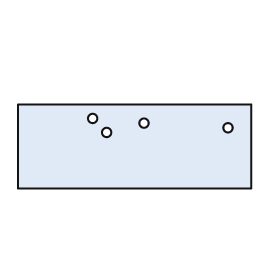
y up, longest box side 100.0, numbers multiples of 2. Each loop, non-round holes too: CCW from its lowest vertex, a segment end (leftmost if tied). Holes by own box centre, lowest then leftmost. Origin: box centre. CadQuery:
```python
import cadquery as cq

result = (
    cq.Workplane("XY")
    .moveTo(-50.0, -18.0)
    .lineTo(50.0, -18.0)
    .lineTo(50.0, 18.0)
    .lineTo(-50.0, 18.0)
    .close()
    .moveTo(-12.0, 6.0)
    .circle(2.0)
    .moveTo(40.0, 8.0)
    .circle(2.0)
    .moveTo(4.0, 10.0)
    .circle(2.0)
    .moveTo(-18.0, 12.0)
    .circle(2.0)
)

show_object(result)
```